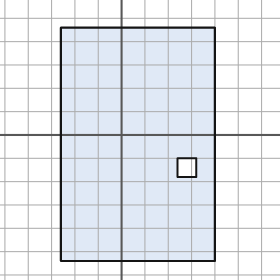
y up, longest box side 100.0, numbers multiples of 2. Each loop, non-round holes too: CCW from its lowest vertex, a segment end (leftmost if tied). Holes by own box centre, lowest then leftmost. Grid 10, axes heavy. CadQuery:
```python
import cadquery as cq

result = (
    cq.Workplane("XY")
    .moveTo(-26.0, -54.0)
    .lineTo(40.0, -54.0)
    .lineTo(40.0, 46.0)
    .lineTo(-26.0, 46.0)
    .close()
    .moveTo(24.0, -18.0)
    .lineTo(32.0, -18.0)
    .lineTo(32.0, -10.0)
    .lineTo(24.0, -10.0)
    .close()
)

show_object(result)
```